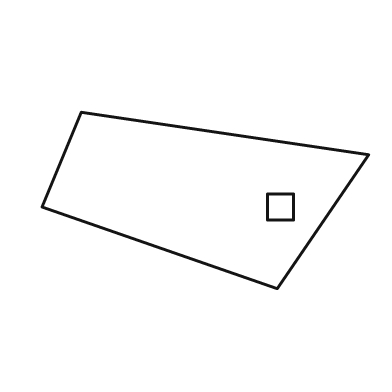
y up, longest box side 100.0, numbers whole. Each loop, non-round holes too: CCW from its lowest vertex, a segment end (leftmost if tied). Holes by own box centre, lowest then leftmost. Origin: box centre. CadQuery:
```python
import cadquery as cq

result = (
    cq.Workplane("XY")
    .moveTo(22.0, -27.0)
    .lineTo(50.0, 14.0)
    .lineTo(-38.0, 27.0)
    .lineTo(-50.0, -2.0)
    .close()
    .moveTo(19.0, -6.0)
    .lineTo(27.0, -6.0)
    .lineTo(27.0, 2.0)
    .lineTo(19.0, 2.0)
    .close()
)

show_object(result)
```